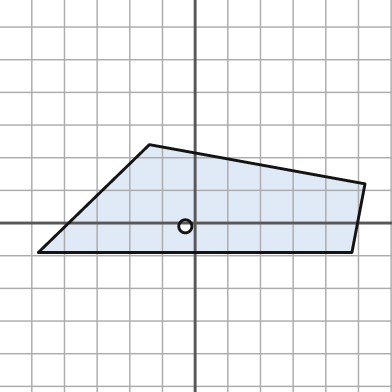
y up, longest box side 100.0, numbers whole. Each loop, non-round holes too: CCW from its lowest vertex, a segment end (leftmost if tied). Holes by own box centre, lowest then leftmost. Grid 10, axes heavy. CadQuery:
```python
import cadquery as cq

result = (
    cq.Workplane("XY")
    .moveTo(-48.0, -9.0)
    .lineTo(48.0, -9.0)
    .lineTo(52.0, 12.0)
    .lineTo(-14.0, 24.0)
    .close()
    .moveTo(-3.0, -1.0)
    .circle(2.0)
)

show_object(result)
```